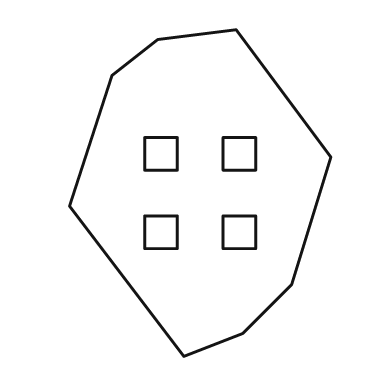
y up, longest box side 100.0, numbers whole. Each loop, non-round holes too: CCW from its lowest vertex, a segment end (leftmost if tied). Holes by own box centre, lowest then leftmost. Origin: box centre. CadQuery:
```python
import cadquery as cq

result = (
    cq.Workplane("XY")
    .moveTo(-5.0, -50.0)
    .lineTo(13.0, -43.0)
    .lineTo(28.0, -28.0)
    .lineTo(40.0, 11.0)
    .lineTo(11.0, 50.0)
    .lineTo(-13.0, 47.0)
    .lineTo(-27.0, 36.0)
    .lineTo(-40.0, -4.0)
    .close()
    .moveTo(-17.0, -17.0)
    .lineTo(-7.0, -17.0)
    .lineTo(-7.0, -7.0)
    .lineTo(-17.0, -7.0)
    .close()
    .moveTo(7.0, -17.0)
    .lineTo(17.0, -17.0)
    .lineTo(17.0, -7.0)
    .lineTo(7.0, -7.0)
    .close()
    .moveTo(-17.0, 7.0)
    .lineTo(-7.0, 7.0)
    .lineTo(-7.0, 17.0)
    .lineTo(-17.0, 17.0)
    .close()
    .moveTo(7.0, 7.0)
    .lineTo(17.0, 7.0)
    .lineTo(17.0, 17.0)
    .lineTo(7.0, 17.0)
    .close()
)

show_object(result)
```